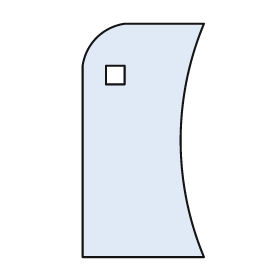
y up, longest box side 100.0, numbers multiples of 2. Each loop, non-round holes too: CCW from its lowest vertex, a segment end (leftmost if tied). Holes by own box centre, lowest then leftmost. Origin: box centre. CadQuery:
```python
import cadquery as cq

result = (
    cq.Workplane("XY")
    .moveTo(-26.0, -50.0)
    .lineTo(26.0, -50.0)
    .threePointArc((16.0, 0.0), (26.0, 50.0))
    .lineTo(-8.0, 50.0)
    .threePointArc((-20.0, 44.0), (-26.0, 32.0))
    .close()
    .moveTo(-16.0, 24.0)
    .lineTo(-8.0, 24.0)
    .lineTo(-8.0, 32.0)
    .lineTo(-16.0, 32.0)
    .close()
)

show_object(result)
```